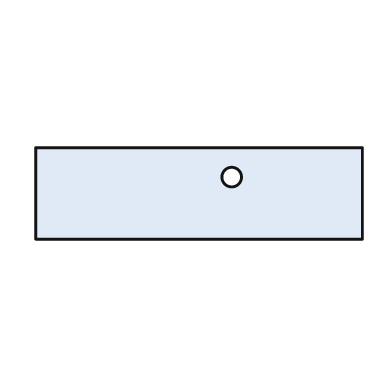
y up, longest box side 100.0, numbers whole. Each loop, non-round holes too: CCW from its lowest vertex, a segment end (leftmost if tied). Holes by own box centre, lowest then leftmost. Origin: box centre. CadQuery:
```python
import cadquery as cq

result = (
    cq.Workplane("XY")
    .moveTo(-50.0, -14.0)
    .lineTo(50.0, -14.0)
    .lineTo(50.0, 14.0)
    .lineTo(-50.0, 14.0)
    .close()
    .moveTo(10.0, 5.0)
    .circle(3.0)
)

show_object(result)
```